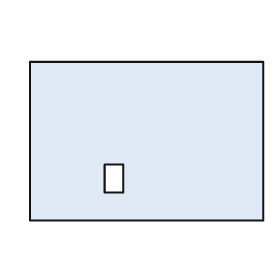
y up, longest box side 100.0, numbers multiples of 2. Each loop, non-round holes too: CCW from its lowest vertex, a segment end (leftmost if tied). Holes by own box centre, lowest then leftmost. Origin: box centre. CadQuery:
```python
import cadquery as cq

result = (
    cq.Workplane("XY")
    .moveTo(-50.0, -34.0)
    .lineTo(50.0, -34.0)
    .lineTo(50.0, 34.0)
    .lineTo(-50.0, 34.0)
    .close()
    .moveTo(-18.0, -22.0)
    .lineTo(-10.0, -22.0)
    .lineTo(-10.0, -10.0)
    .lineTo(-18.0, -10.0)
    .close()
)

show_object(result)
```